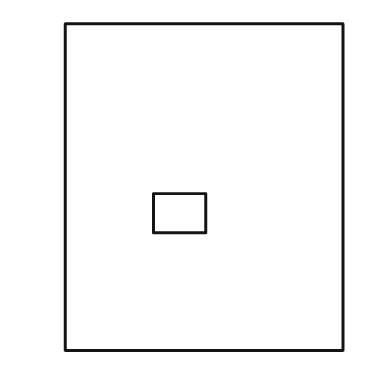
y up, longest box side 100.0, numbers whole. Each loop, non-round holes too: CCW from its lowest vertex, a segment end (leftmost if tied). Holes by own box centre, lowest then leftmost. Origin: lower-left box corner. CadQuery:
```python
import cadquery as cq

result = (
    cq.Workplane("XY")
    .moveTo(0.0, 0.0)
    .lineTo(85.0, 0.0)
    .lineTo(85.0, 100.0)
    .lineTo(0.0, 100.0)
    .close()
    .moveTo(27.0, 36.0)
    .lineTo(43.0, 36.0)
    .lineTo(43.0, 48.0)
    .lineTo(27.0, 48.0)
    .close()
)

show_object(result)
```